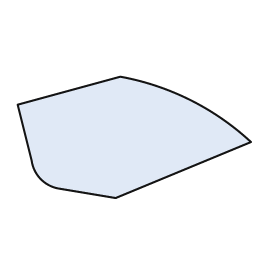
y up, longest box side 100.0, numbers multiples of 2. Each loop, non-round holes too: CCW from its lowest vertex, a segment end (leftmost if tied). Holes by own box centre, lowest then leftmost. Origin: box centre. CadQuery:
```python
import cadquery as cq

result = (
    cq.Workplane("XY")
    .moveTo(-8.0, -26.0)
    .lineTo(50.0, -2.0)
    .threePointArc((24.0, 16.0), (-6.0, 26.0))
    .lineTo(-50.0, 14.0)
    .lineTo(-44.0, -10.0)
    .threePointArc((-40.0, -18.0), (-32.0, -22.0))
    .close()
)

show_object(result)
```